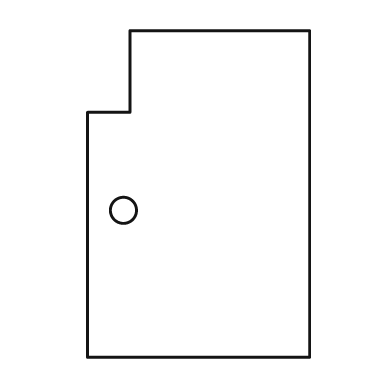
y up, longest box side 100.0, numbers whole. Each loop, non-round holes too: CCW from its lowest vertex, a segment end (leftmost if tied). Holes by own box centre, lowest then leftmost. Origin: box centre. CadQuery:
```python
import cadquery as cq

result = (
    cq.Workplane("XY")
    .moveTo(-34.0, -50.0)
    .lineTo(34.0, -50.0)
    .lineTo(34.0, 50.0)
    .lineTo(-21.0, 50.0)
    .lineTo(-21.0, 25.0)
    .lineTo(-34.0, 25.0)
    .close()
    .moveTo(-23.0, -5.0)
    .circle(4.0)
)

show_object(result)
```